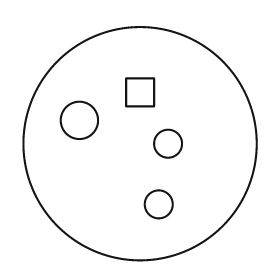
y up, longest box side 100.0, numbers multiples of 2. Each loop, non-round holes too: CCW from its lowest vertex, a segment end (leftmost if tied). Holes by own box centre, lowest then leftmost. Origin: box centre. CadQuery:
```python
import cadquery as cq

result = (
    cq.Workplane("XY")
    .moveTo(0.0, 0.0)
    .circle(50.0)
    .moveTo(8.0, -26.0)
    .circle(6.0)
    .moveTo(12.0, 0.0)
    .circle(6.0)
    .moveTo(-26.0, 10.0)
    .circle(8.0)
    .moveTo(-6.0, 16.0)
    .lineTo(6.0, 16.0)
    .lineTo(6.0, 28.0)
    .lineTo(-6.0, 28.0)
    .close()
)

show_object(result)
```